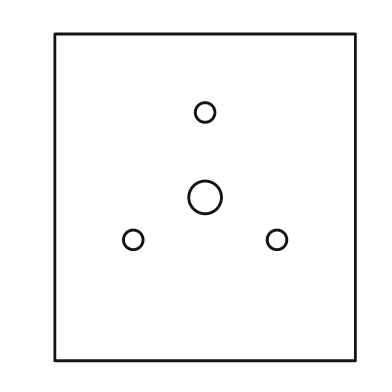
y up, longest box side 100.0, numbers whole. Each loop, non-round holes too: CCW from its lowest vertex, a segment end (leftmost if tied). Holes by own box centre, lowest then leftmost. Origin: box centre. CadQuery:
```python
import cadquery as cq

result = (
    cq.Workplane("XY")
    .moveTo(-46.0, -50.0)
    .lineTo(46.0, -50.0)
    .lineTo(46.0, 50.0)
    .lineTo(-46.0, 50.0)
    .close()
    .moveTo(-22.0, -13.0)
    .circle(3.0)
    .moveTo(22.0, -13.0)
    .circle(3.0)
    .moveTo(0.0, 0.0)
    .circle(5.0)
    .moveTo(0.0, 26.0)
    .circle(3.0)
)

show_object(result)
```